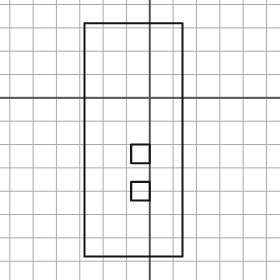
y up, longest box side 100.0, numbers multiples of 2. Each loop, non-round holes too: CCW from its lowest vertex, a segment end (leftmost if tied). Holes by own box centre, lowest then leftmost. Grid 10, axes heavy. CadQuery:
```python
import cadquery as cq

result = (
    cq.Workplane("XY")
    .moveTo(-28.0, -68.0)
    .lineTo(14.0, -68.0)
    .lineTo(14.0, 32.0)
    .lineTo(-28.0, 32.0)
    .close()
    .moveTo(-8.0, -44.0)
    .lineTo(0.0, -44.0)
    .lineTo(0.0, -36.0)
    .lineTo(-8.0, -36.0)
    .close()
    .moveTo(-8.0, -28.0)
    .lineTo(0.0, -28.0)
    .lineTo(0.0, -20.0)
    .lineTo(-8.0, -20.0)
    .close()
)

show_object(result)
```